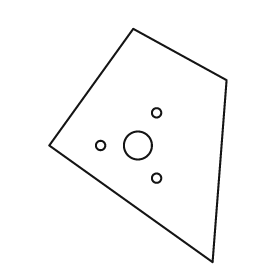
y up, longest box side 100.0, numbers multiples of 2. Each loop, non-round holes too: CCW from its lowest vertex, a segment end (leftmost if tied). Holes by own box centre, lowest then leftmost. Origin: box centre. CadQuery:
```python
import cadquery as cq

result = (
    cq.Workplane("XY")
    .moveTo(32.0, -50.0)
    .lineTo(38.0, 28.0)
    .lineTo(-2.0, 50.0)
    .lineTo(-38.0, 0.0)
    .close()
    .moveTo(8.0, -14.0)
    .circle(2.0)
    .moveTo(-16.0, 0.0)
    .circle(2.0)
    .moveTo(0.0, 0.0)
    .circle(6.0)
    .moveTo(8.0, 14.0)
    .circle(2.0)
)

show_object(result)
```